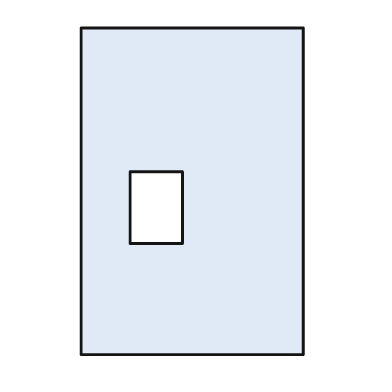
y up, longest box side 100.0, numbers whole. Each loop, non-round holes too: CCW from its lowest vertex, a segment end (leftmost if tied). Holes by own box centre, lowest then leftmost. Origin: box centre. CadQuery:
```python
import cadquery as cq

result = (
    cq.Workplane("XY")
    .moveTo(-34.0, -50.0)
    .lineTo(34.0, -50.0)
    .lineTo(34.0, 50.0)
    .lineTo(-34.0, 50.0)
    .close()
    .moveTo(-19.0, -16.0)
    .lineTo(-3.0, -16.0)
    .lineTo(-3.0, 6.0)
    .lineTo(-19.0, 6.0)
    .close()
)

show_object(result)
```